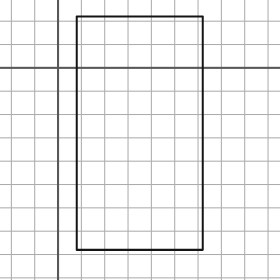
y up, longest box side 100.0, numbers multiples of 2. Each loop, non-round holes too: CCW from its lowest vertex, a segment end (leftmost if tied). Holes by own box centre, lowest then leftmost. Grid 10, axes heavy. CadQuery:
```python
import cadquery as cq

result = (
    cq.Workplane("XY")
    .moveTo(8.0, -78.0)
    .lineTo(62.0, -78.0)
    .lineTo(62.0, 22.0)
    .lineTo(8.0, 22.0)
    .close()
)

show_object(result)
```